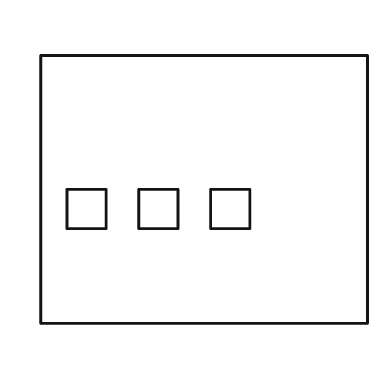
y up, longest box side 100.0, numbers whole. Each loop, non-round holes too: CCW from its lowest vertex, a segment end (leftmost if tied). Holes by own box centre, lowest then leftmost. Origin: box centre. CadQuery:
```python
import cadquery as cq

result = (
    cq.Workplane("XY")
    .moveTo(-50.0, -41.0)
    .lineTo(50.0, -41.0)
    .lineTo(50.0, 41.0)
    .lineTo(-50.0, 41.0)
    .close()
    .moveTo(-42.0, -12.0)
    .lineTo(-30.0, -12.0)
    .lineTo(-30.0, 0.0)
    .lineTo(-42.0, 0.0)
    .close()
    .moveTo(-20.0, -12.0)
    .lineTo(-8.0, -12.0)
    .lineTo(-8.0, 0.0)
    .lineTo(-20.0, 0.0)
    .close()
    .moveTo(2.0, -12.0)
    .lineTo(14.0, -12.0)
    .lineTo(14.0, 0.0)
    .lineTo(2.0, 0.0)
    .close()
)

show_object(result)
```